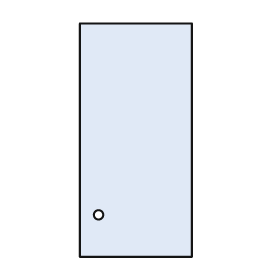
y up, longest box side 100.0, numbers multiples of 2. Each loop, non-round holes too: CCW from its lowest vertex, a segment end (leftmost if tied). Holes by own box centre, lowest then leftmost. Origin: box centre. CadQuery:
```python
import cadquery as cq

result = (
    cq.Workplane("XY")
    .moveTo(-24.0, -50.0)
    .lineTo(24.0, -50.0)
    .lineTo(24.0, 50.0)
    .lineTo(-24.0, 50.0)
    .close()
    .moveTo(-16.0, -32.0)
    .circle(2.0)
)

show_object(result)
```